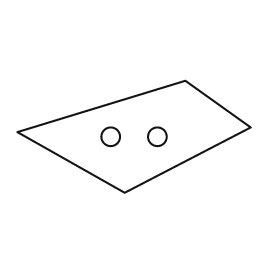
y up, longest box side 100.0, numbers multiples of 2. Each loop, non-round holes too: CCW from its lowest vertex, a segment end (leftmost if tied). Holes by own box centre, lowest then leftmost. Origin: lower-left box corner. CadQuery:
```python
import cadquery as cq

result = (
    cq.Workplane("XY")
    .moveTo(46.0, 0.0)
    .lineTo(100.0, 28.0)
    .lineTo(72.0, 48.0)
    .lineTo(0.0, 26.0)
    .close()
    .moveTo(40.0, 24.0)
    .circle(4.0)
    .moveTo(60.0, 24.0)
    .circle(4.0)
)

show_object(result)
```